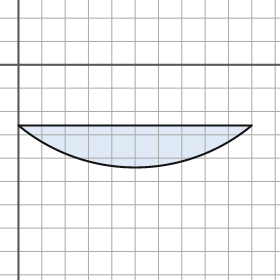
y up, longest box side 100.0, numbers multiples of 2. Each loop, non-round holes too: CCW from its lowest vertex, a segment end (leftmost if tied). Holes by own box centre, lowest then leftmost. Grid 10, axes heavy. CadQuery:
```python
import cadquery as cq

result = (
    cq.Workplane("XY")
    .moveTo(0.0, -26.0)
    .threePointArc((50.0, -44.0), (100.0, -26.0))
    .close()
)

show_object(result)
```